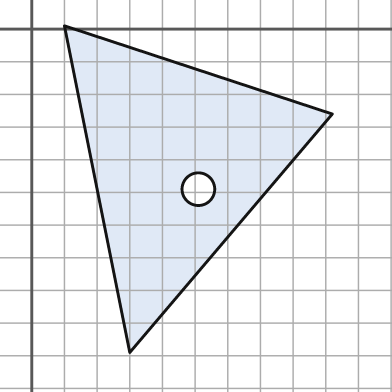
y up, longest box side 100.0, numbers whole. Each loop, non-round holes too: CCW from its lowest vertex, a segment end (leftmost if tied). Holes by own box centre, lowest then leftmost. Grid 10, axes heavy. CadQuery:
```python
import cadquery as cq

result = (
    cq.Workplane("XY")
    .moveTo(30.0, -99.0)
    .lineTo(92.0, -26.0)
    .lineTo(10.0, 1.0)
    .close()
    .moveTo(51.0, -49.0)
    .circle(5.0)
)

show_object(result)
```